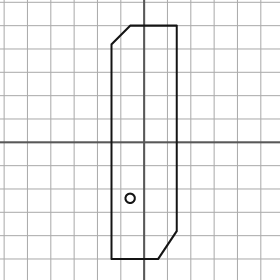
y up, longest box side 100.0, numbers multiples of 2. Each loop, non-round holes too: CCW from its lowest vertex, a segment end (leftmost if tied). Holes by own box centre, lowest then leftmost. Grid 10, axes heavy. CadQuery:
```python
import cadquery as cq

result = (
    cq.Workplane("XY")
    .moveTo(-14.0, -50.0)
    .lineTo(6.0, -50.0)
    .lineTo(14.0, -38.0)
    .lineTo(14.0, 50.0)
    .lineTo(-6.0, 50.0)
    .lineTo(-14.0, 42.0)
    .close()
    .moveTo(-6.0, -24.0)
    .circle(2.0)
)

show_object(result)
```